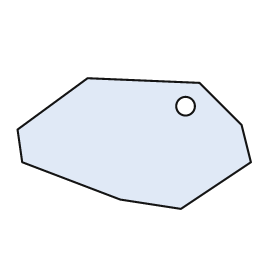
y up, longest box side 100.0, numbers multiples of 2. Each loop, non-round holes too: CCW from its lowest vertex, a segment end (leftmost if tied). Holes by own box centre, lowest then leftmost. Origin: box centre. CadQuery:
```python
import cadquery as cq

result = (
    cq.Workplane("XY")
    .moveTo(20.0, -28.0)
    .lineTo(50.0, -8.0)
    .lineTo(46.0, 8.0)
    .lineTo(28.0, 26.0)
    .lineTo(-20.0, 28.0)
    .lineTo(-50.0, 6.0)
    .lineTo(-48.0, -8.0)
    .lineTo(-6.0, -24.0)
    .close()
    .moveTo(22.0, 16.0)
    .circle(4.0)
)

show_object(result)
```